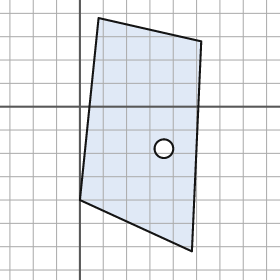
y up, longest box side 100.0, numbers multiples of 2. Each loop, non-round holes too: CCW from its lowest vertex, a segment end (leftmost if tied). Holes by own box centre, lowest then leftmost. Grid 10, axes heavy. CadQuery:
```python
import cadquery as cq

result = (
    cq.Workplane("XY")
    .moveTo(48.0, -62.0)
    .lineTo(52.0, 28.0)
    .lineTo(8.0, 38.0)
    .lineTo(0.0, -40.0)
    .close()
    .moveTo(36.0, -18.0)
    .circle(4.0)
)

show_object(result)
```